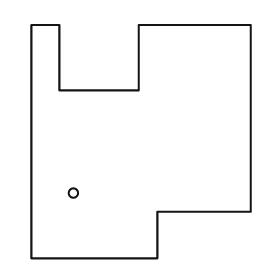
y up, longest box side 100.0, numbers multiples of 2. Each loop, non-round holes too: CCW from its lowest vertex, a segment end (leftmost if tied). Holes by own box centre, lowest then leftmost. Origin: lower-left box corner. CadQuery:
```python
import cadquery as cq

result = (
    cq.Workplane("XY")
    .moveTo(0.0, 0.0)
    .lineTo(54.0, 0.0)
    .lineTo(54.0, 20.0)
    .lineTo(94.0, 20.0)
    .lineTo(94.0, 100.0)
    .lineTo(46.0, 100.0)
    .lineTo(46.0, 72.0)
    .lineTo(12.0, 72.0)
    .lineTo(12.0, 100.0)
    .lineTo(0.0, 100.0)
    .close()
    .moveTo(18.0, 28.0)
    .circle(2.0)
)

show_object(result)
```